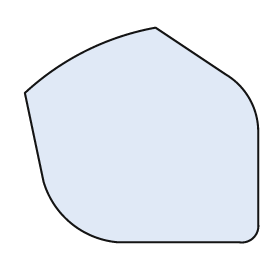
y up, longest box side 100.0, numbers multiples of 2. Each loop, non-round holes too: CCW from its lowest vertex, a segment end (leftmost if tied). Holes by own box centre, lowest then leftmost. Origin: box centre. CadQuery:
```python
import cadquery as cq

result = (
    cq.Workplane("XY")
    .moveTo(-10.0, -46.0)
    .lineTo(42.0, -46.0)
    .threePointArc((48.0, -44.0), (50.0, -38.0))
    .lineTo(50.0, 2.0)
    .threePointArc((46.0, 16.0), (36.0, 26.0))
    .lineTo(6.0, 46.0)
    .threePointArc((-24.0, 36.0), (-50.0, 18.0))
    .lineTo(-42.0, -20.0)
    .threePointArc((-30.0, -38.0), (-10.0, -46.0))
    .close()
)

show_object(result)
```